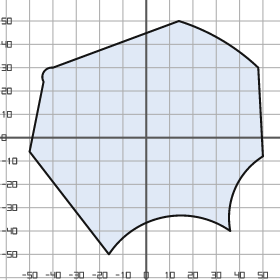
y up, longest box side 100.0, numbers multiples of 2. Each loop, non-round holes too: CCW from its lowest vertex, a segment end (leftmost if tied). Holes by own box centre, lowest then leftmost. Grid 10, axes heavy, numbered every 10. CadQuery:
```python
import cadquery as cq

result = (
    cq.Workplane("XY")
    .moveTo(-16.0, -50.0)
    .threePointArc((8.0, -34.0), (36.0, -40.0))
    .threePointArc((38.0, -22.0), (50.0, -8.0))
    .lineTo(48.0, 30.0)
    .threePointArc((32.0, 42.0), (14.0, 50.0))
    .lineTo(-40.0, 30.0)
    .threePointArc((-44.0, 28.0), (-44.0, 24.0))
    .lineTo(-50.0, -6.0)
    .close()
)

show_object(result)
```